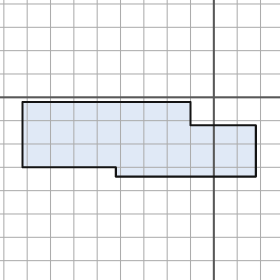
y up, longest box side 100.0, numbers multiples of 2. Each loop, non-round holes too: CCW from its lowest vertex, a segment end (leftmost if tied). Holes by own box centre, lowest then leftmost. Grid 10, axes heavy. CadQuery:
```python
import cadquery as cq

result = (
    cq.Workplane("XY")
    .moveTo(-42.0, -34.0)
    .lineTo(18.0, -34.0)
    .lineTo(18.0, -12.0)
    .lineTo(-10.0, -12.0)
    .lineTo(-10.0, -2.0)
    .lineTo(-82.0, -2.0)
    .lineTo(-82.0, -30.0)
    .lineTo(-42.0, -30.0)
    .close()
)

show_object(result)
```